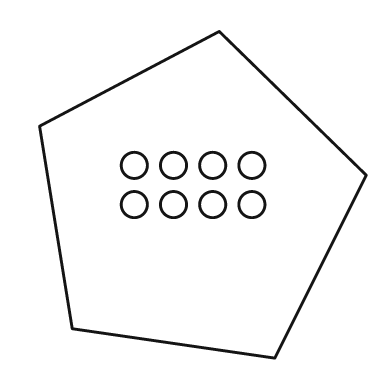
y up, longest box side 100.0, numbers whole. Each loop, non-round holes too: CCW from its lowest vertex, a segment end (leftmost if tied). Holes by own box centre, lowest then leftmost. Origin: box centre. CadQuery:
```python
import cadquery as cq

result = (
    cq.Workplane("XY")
    .moveTo(22.0, -50.0)
    .lineTo(50.0, 6.0)
    .lineTo(5.0, 50.0)
    .lineTo(-50.0, 21.0)
    .lineTo(-40.0, -41.0)
    .close()
    .moveTo(-21.0, -3.0)
    .circle(4.0)
    .moveTo(-9.0, -3.0)
    .circle(4.0)
    .moveTo(3.0, -3.0)
    .circle(4.0)
    .moveTo(15.0, -3.0)
    .circle(4.0)
    .moveTo(-21.0, 9.0)
    .circle(4.0)
    .moveTo(-9.0, 9.0)
    .circle(4.0)
    .moveTo(3.0, 9.0)
    .circle(4.0)
    .moveTo(15.0, 9.0)
    .circle(4.0)
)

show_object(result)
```